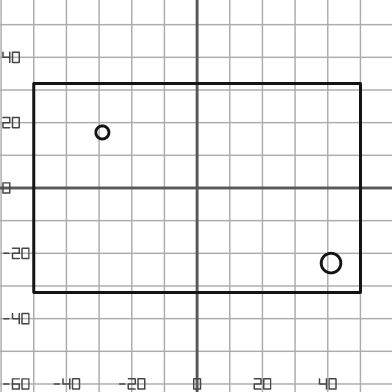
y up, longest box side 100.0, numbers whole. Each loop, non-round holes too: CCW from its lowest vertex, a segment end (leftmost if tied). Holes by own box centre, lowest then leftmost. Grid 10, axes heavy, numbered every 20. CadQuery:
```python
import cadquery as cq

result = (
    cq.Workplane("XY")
    .moveTo(-50.0, -32.0)
    .lineTo(50.0, -32.0)
    .lineTo(50.0, 32.0)
    .lineTo(-50.0, 32.0)
    .close()
    .moveTo(41.0, -23.0)
    .circle(3.0)
    .moveTo(-29.0, 17.0)
    .circle(2.0)
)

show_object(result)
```